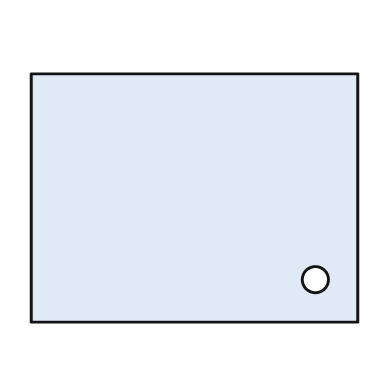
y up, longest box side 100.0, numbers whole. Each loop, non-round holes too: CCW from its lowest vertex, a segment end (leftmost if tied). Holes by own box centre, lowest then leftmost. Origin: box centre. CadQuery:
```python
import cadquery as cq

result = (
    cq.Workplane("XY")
    .moveTo(-50.0, -38.0)
    .lineTo(50.0, -38.0)
    .lineTo(50.0, 38.0)
    .lineTo(-50.0, 38.0)
    .close()
    .moveTo(37.0, -25.0)
    .circle(4.0)
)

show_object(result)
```